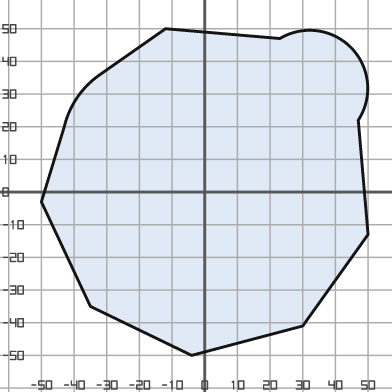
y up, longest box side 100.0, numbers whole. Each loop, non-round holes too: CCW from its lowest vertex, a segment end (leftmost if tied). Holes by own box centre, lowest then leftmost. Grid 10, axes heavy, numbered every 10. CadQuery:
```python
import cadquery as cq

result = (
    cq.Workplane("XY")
    .moveTo(-4.0, -50.0)
    .lineTo(30.0, -41.0)
    .lineTo(50.0, -13.0)
    .lineTo(47.0, 22.0)
    .threePointArc((45.0, 44.0), (23.0, 47.0))
    .lineTo(-12.0, 50.0)
    .lineTo(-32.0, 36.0)
    .threePointArc((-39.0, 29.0), (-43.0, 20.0))
    .lineTo(-50.0, -3.0)
    .lineTo(-35.0, -35.0)
    .close()
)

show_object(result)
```